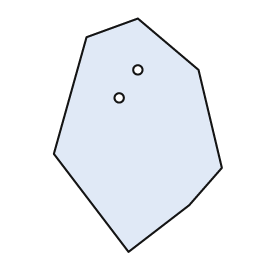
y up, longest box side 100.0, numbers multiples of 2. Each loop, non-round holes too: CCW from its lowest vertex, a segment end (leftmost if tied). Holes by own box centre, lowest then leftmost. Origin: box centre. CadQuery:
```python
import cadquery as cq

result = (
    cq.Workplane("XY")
    .moveTo(-4.0, -50.0)
    .lineTo(22.0, -30.0)
    .lineTo(36.0, -14.0)
    .lineTo(26.0, 28.0)
    .lineTo(0.0, 50.0)
    .lineTo(-22.0, 42.0)
    .lineTo(-36.0, -8.0)
    .close()
    .moveTo(-8.0, 16.0)
    .circle(2.0)
    .moveTo(0.0, 28.0)
    .circle(2.0)
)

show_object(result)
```